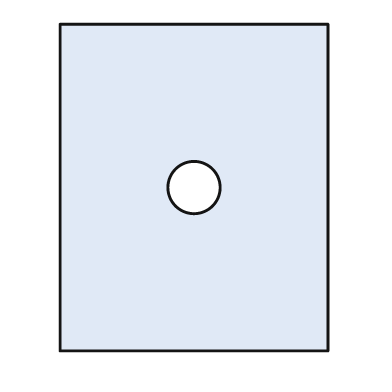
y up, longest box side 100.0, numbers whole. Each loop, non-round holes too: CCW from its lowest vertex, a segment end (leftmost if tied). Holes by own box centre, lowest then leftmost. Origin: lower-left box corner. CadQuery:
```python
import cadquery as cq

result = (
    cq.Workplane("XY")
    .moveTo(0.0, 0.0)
    .lineTo(82.0, 0.0)
    .lineTo(82.0, 100.0)
    .lineTo(0.0, 100.0)
    .close()
    .moveTo(41.0, 50.0)
    .circle(8.0)
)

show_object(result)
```